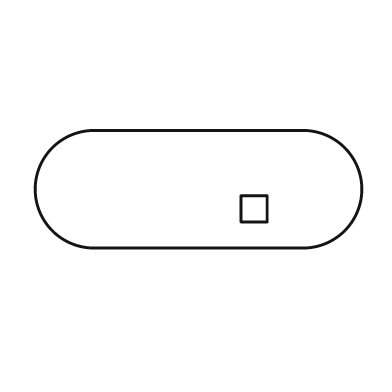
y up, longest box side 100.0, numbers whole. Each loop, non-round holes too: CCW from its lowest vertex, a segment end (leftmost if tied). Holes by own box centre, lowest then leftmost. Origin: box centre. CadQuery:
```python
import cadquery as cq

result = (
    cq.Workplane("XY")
    .moveTo(-32.0, -18.0)
    .lineTo(32.0, -18.0)
    .threePointArc((50.0, 0.0), (32.0, 18.0))
    .lineTo(-32.0, 18.0)
    .threePointArc((-50.0, 0.0), (-32.0, -18.0))
    .close()
    .moveTo(13.0, -10.0)
    .lineTo(21.0, -10.0)
    .lineTo(21.0, -2.0)
    .lineTo(13.0, -2.0)
    .close()
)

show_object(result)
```